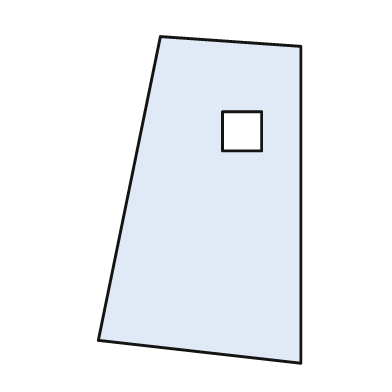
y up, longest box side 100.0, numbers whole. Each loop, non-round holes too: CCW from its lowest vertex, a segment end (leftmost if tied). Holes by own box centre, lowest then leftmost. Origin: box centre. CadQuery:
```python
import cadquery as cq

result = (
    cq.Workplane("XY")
    .moveTo(31.0, -50.0)
    .lineTo(31.0, 47.0)
    .lineTo(-12.0, 50.0)
    .lineTo(-31.0, -43.0)
    .close()
    .moveTo(7.0, 15.0)
    .lineTo(19.0, 15.0)
    .lineTo(19.0, 27.0)
    .lineTo(7.0, 27.0)
    .close()
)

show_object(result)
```